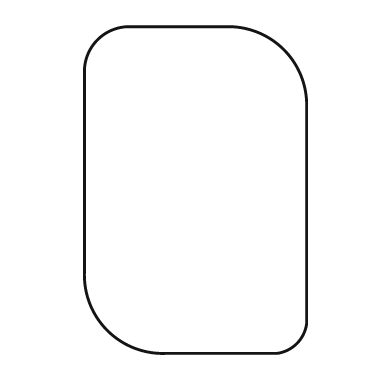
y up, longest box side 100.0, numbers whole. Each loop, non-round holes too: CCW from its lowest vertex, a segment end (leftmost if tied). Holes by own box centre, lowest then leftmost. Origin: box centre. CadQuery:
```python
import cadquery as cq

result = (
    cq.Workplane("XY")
    .moveTo(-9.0, -50.0)
    .lineTo(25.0, -50.0)
    .threePointArc((31.0, -47.0), (34.0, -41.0))
    .lineTo(34.0, 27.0)
    .threePointArc((27.0, 43.0), (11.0, 50.0))
    .lineTo(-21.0, 50.0)
    .threePointArc((-30.0, 46.0), (-34.0, 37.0))
    .lineTo(-34.0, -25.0)
    .threePointArc((-27.0, -43.0), (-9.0, -50.0))
    .close()
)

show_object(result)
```